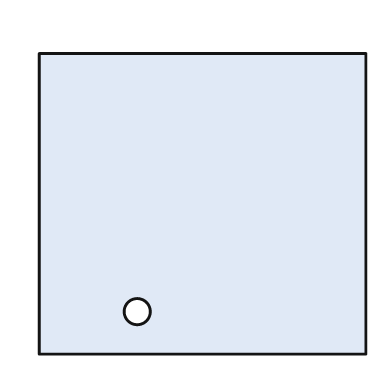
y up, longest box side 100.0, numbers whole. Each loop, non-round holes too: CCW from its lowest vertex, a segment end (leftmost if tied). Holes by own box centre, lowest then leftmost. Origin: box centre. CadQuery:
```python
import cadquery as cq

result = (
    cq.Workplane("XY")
    .moveTo(-50.0, -46.0)
    .lineTo(50.0, -46.0)
    .lineTo(50.0, 46.0)
    .lineTo(-50.0, 46.0)
    .close()
    .moveTo(-20.0, -33.0)
    .circle(4.0)
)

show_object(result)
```